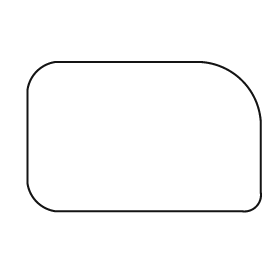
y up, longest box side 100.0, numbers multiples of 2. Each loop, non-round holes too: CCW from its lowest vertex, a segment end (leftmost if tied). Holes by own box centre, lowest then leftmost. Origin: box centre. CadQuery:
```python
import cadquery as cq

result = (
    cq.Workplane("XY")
    .moveTo(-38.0, -32.0)
    .lineTo(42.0, -32.0)
    .threePointArc((48.0, -30.0), (50.0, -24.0))
    .lineTo(50.0, 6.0)
    .threePointArc((42.0, 24.0), (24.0, 32.0))
    .lineTo(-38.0, 32.0)
    .threePointArc((-46.0, 28.0), (-50.0, 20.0))
    .lineTo(-50.0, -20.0)
    .threePointArc((-46.0, -28.0), (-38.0, -32.0))
    .close()
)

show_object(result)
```